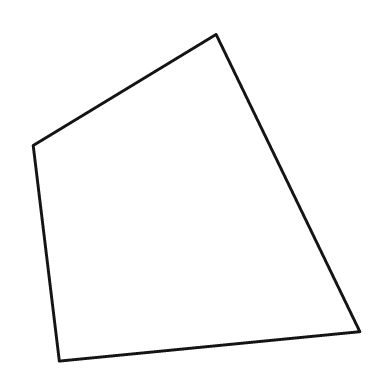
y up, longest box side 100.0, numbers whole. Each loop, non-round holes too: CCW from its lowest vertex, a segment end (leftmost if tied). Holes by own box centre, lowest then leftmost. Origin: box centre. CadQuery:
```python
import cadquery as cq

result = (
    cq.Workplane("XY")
    .moveTo(-42.0, -50.0)
    .lineTo(50.0, -41.0)
    .lineTo(6.0, 50.0)
    .lineTo(-50.0, 16.0)
    .close()
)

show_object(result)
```